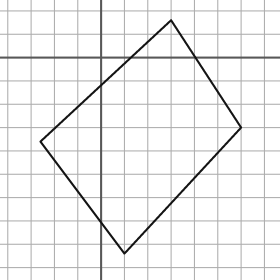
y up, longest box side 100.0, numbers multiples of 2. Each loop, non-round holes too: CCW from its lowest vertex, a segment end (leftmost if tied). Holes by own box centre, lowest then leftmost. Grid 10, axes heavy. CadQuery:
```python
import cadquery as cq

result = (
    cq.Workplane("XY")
    .moveTo(10.0, -84.0)
    .lineTo(60.0, -30.0)
    .lineTo(30.0, 16.0)
    .lineTo(-26.0, -36.0)
    .close()
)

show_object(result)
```